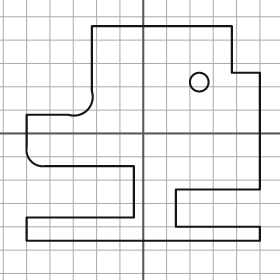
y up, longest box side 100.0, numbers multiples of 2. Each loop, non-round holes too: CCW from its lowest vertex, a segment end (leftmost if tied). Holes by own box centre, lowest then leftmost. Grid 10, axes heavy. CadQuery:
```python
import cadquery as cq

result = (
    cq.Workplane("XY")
    .moveTo(-50.0, -46.0)
    .lineTo(50.0, -46.0)
    .lineTo(50.0, -40.0)
    .lineTo(14.0, -40.0)
    .lineTo(14.0, -24.0)
    .lineTo(50.0, -24.0)
    .lineTo(50.0, 26.0)
    .lineTo(38.0, 26.0)
    .lineTo(38.0, 46.0)
    .lineTo(-22.0, 46.0)
    .lineTo(-22.0, 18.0)
    .threePointArc((-24.0, 10.0), (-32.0, 8.0))
    .lineTo(-50.0, 8.0)
    .lineTo(-50.0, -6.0)
    .threePointArc((-48.0, -12.0), (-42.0, -14.0))
    .lineTo(-4.0, -14.0)
    .lineTo(-4.0, -36.0)
    .lineTo(-50.0, -36.0)
    .close()
    .moveTo(24.0, 22.0)
    .circle(4.0)
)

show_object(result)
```